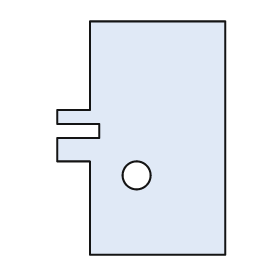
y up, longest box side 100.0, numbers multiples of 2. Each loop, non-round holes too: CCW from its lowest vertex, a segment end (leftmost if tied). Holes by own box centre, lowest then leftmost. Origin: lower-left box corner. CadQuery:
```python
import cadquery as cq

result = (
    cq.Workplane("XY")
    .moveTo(14.0, 0.0)
    .lineTo(72.0, 0.0)
    .lineTo(72.0, 100.0)
    .lineTo(14.0, 100.0)
    .lineTo(14.0, 62.0)
    .lineTo(0.0, 62.0)
    .lineTo(0.0, 56.0)
    .lineTo(18.0, 56.0)
    .lineTo(18.0, 50.0)
    .lineTo(0.0, 50.0)
    .lineTo(0.0, 40.0)
    .lineTo(14.0, 40.0)
    .close()
    .moveTo(34.0, 34.0)
    .circle(6.0)
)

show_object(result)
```